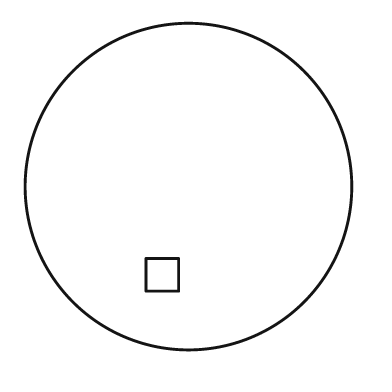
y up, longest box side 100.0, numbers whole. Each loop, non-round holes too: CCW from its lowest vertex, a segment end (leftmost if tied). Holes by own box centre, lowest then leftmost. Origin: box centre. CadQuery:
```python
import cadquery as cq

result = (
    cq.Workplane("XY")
    .moveTo(0.0, 0.0)
    .circle(50.0)
    .moveTo(-13.0, -32.0)
    .lineTo(-3.0, -32.0)
    .lineTo(-3.0, -22.0)
    .lineTo(-13.0, -22.0)
    .close()
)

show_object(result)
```